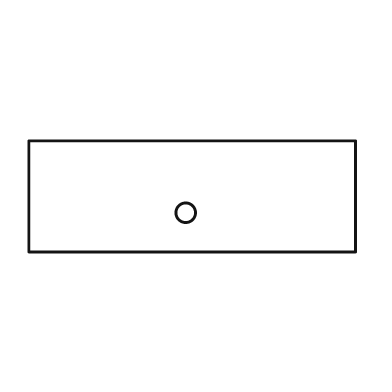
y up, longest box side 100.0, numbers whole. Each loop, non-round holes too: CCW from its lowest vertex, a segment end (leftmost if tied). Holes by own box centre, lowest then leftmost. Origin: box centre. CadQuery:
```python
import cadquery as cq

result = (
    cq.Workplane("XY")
    .moveTo(-50.0, -17.0)
    .lineTo(50.0, -17.0)
    .lineTo(50.0, 17.0)
    .lineTo(-50.0, 17.0)
    .close()
    .moveTo(-2.0, -5.0)
    .circle(3.0)
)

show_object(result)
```